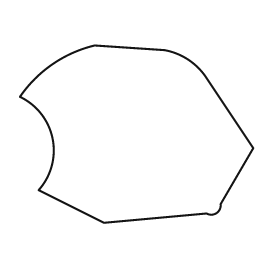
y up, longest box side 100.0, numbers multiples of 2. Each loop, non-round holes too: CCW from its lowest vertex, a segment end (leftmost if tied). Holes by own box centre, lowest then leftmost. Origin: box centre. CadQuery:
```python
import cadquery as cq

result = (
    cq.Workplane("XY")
    .moveTo(-14.0, -38.0)
    .lineTo(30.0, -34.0)
    .threePointArc((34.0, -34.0), (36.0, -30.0))
    .lineTo(50.0, -6.0)
    .lineTo(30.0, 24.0)
    .threePointArc((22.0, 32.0), (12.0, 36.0))
    .lineTo(-18.0, 38.0)
    .threePointArc((-36.0, 30.0), (-50.0, 16.0))
    .threePointArc((-36.0, -2.0), (-42.0, -24.0))
    .close()
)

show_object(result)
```